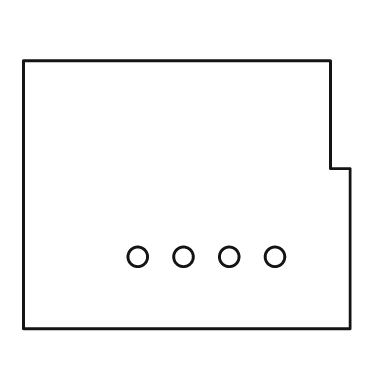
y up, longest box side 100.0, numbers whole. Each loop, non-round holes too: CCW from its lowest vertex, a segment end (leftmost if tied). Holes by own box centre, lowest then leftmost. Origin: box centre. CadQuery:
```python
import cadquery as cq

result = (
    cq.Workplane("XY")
    .moveTo(-50.0, -41.0)
    .lineTo(50.0, -41.0)
    .lineTo(50.0, 8.0)
    .lineTo(44.0, 8.0)
    .lineTo(44.0, 41.0)
    .lineTo(-50.0, 41.0)
    .close()
    .moveTo(-15.0, -19.0)
    .circle(3.0)
    .moveTo(-1.0, -19.0)
    .circle(3.0)
    .moveTo(13.0, -19.0)
    .circle(3.0)
    .moveTo(27.0, -19.0)
    .circle(3.0)
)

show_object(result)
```